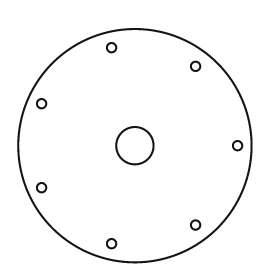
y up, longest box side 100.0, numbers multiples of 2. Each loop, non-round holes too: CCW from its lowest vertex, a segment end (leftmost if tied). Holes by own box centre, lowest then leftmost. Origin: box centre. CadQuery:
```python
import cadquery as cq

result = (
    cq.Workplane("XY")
    .moveTo(0.0, 0.0)
    .circle(50.0)
    .moveTo(-10.0, -42.0)
    .circle(2.0)
    .moveTo(26.0, -34.0)
    .circle(2.0)
    .moveTo(-40.0, -18.0)
    .circle(2.0)
    .moveTo(0.0, 0.0)
    .circle(8.0)
    .moveTo(44.0, 0.0)
    .circle(2.0)
    .moveTo(-40.0, 18.0)
    .circle(2.0)
    .moveTo(26.0, 34.0)
    .circle(2.0)
    .moveTo(-10.0, 42.0)
    .circle(2.0)
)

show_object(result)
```